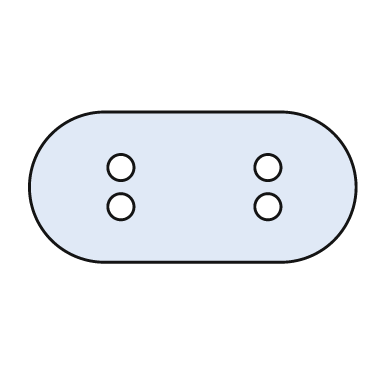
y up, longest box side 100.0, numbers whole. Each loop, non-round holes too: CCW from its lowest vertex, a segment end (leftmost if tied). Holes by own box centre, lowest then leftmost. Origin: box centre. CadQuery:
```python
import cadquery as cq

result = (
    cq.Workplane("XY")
    .moveTo(-27.0, -23.0)
    .lineTo(27.0, -23.0)
    .threePointArc((50.0, 0.0), (27.0, 23.0))
    .lineTo(-27.0, 23.0)
    .threePointArc((-50.0, 0.0), (-27.0, -23.0))
    .close()
    .moveTo(-22.0, -6.0)
    .circle(4.0)
    .moveTo(23.0, -6.0)
    .circle(4.0)
    .moveTo(-22.0, 6.0)
    .circle(4.0)
    .moveTo(23.0, 6.0)
    .circle(4.0)
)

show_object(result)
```